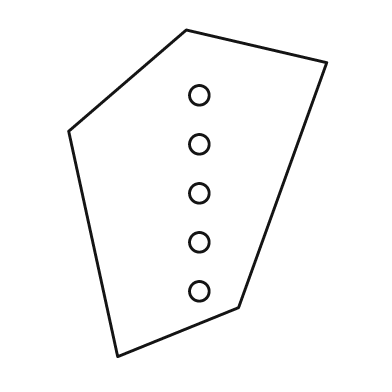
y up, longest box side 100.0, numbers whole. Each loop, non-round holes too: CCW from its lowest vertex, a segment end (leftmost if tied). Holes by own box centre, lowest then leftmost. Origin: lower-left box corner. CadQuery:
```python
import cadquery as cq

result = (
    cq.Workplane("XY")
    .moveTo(15.0, 0.0)
    .lineTo(52.0, 15.0)
    .lineTo(79.0, 90.0)
    .lineTo(36.0, 100.0)
    .lineTo(0.0, 69.0)
    .close()
    .moveTo(40.0, 20.0)
    .circle(3.0)
    .moveTo(40.0, 35.0)
    .circle(3.0)
    .moveTo(40.0, 50.0)
    .circle(3.0)
    .moveTo(40.0, 65.0)
    .circle(3.0)
    .moveTo(40.0, 80.0)
    .circle(3.0)
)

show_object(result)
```